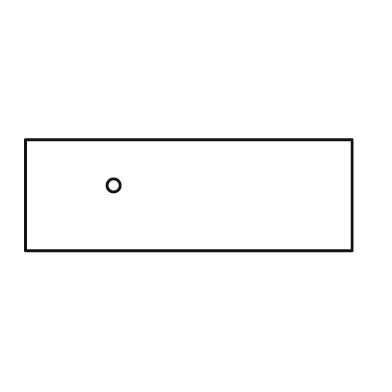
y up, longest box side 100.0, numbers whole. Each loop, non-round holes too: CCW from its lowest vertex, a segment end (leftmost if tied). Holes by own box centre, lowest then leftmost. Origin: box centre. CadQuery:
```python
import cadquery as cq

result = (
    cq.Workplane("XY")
    .moveTo(-50.0, -17.0)
    .lineTo(50.0, -17.0)
    .lineTo(50.0, 17.0)
    .lineTo(-50.0, 17.0)
    .close()
    .moveTo(-23.0, 3.0)
    .circle(2.0)
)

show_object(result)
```